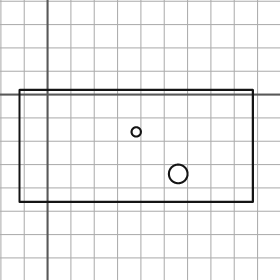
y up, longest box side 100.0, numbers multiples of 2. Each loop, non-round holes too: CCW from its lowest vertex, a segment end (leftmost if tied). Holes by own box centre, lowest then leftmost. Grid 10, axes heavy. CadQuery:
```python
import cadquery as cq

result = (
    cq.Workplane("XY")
    .moveTo(-12.0, -46.0)
    .lineTo(88.0, -46.0)
    .lineTo(88.0, 2.0)
    .lineTo(-12.0, 2.0)
    .close()
    .moveTo(56.0, -34.0)
    .circle(4.0)
    .moveTo(38.0, -16.0)
    .circle(2.0)
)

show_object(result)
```